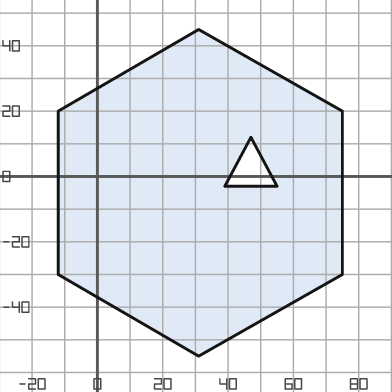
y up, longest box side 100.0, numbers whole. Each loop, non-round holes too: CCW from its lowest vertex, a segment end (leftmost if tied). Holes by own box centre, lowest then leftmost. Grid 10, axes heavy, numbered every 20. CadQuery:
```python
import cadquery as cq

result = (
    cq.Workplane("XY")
    .moveTo(31.0, -55.0)
    .lineTo(75.0, -30.0)
    .lineTo(75.0, 20.0)
    .lineTo(31.0, 45.0)
    .lineTo(-12.0, 20.0)
    .lineTo(-12.0, -30.0)
    .close()
    .moveTo(39.0, -3.0)
    .lineTo(55.0, -3.0)
    .lineTo(47.0, 12.0)
    .close()
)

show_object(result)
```